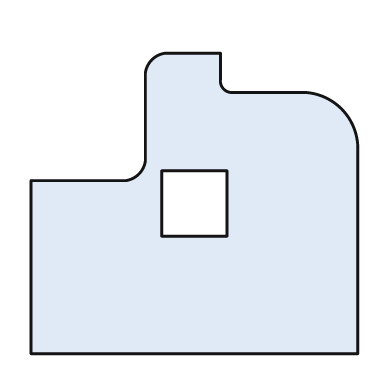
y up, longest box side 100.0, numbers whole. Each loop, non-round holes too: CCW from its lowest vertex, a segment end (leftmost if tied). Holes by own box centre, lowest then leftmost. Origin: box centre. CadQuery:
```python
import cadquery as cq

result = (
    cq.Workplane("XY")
    .moveTo(-50.0, -46.0)
    .lineTo(50.0, -46.0)
    .lineTo(50.0, 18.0)
    .threePointArc((45.0, 29.0), (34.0, 34.0))
    .lineTo(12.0, 34.0)
    .threePointArc((9.0, 35.0), (8.0, 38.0))
    .lineTo(8.0, 46.0)
    .lineTo(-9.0, 46.0)
    .threePointArc((-13.0, 44.0), (-15.0, 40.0))
    .lineTo(-15.0, 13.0)
    .threePointArc((-17.0, 9.0), (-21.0, 7.0))
    .lineTo(-50.0, 7.0)
    .close()
    .moveTo(-10.0, -10.0)
    .lineTo(10.0, -10.0)
    .lineTo(10.0, 10.0)
    .lineTo(-10.0, 10.0)
    .close()
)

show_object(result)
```